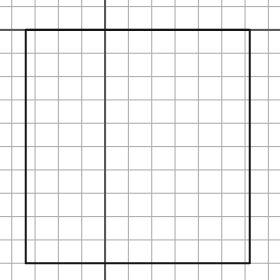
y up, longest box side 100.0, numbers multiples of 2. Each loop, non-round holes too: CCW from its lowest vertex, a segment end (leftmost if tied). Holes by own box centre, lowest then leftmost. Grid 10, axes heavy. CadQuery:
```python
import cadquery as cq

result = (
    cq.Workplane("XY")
    .moveTo(-34.0, -100.0)
    .lineTo(62.0, -100.0)
    .lineTo(62.0, 0.0)
    .lineTo(-34.0, 0.0)
    .close()
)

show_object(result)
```